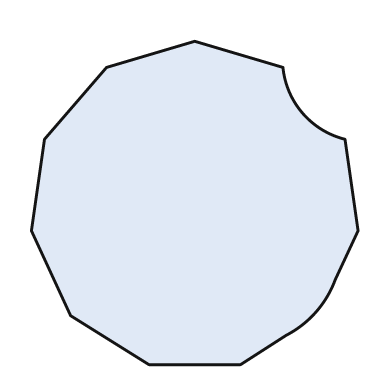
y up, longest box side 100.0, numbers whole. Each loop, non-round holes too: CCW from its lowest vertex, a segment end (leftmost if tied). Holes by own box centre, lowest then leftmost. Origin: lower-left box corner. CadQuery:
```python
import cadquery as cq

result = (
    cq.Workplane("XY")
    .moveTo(36.0, 0.0)
    .lineTo(64.0, 0.0)
    .lineTo(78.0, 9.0)
    .threePointArc((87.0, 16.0), (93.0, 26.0))
    .lineTo(100.0, 41.0)
    .lineTo(96.0, 69.0)
    .threePointArc((83.0, 77.0), (77.0, 91.0))
    .lineTo(50.0, 99.0)
    .lineTo(23.0, 91.0)
    .lineTo(4.0, 69.0)
    .lineTo(0.0, 41.0)
    .lineTo(12.0, 15.0)
    .close()
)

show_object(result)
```